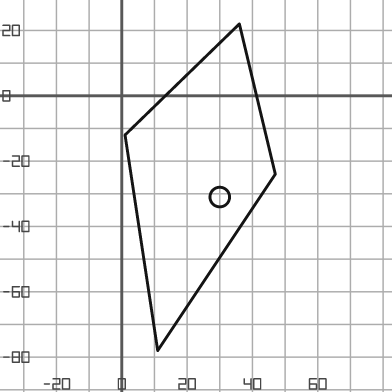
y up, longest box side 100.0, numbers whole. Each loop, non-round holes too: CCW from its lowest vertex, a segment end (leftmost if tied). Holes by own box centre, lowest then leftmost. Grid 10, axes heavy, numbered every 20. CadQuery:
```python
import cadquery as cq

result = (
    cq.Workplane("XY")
    .moveTo(11.0, -78.0)
    .lineTo(47.0, -24.0)
    .lineTo(36.0, 22.0)
    .lineTo(1.0, -12.0)
    .close()
    .moveTo(30.0, -31.0)
    .circle(3.0)
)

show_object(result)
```